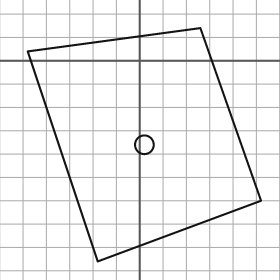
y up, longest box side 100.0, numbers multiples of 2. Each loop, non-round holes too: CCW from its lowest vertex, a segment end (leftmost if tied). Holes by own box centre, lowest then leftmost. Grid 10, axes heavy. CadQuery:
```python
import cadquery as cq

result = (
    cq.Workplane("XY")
    .moveTo(-18.0, -86.0)
    .lineTo(52.0, -60.0)
    .lineTo(26.0, 14.0)
    .lineTo(-48.0, 4.0)
    .close()
    .moveTo(2.0, -36.0)
    .circle(4.0)
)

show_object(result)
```